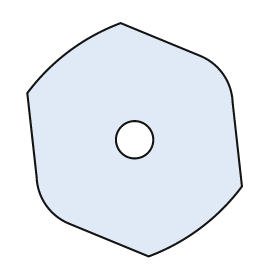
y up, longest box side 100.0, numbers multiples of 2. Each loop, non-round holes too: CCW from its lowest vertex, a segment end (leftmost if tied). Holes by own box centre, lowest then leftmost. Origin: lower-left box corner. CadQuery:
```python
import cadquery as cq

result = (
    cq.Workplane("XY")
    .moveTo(52.0, 0.0)
    .threePointArc((74.0, 12.0), (92.0, 30.0))
    .lineTo(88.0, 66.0)
    .threePointArc((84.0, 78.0), (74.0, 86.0))
    .lineTo(40.0, 100.0)
    .threePointArc((18.0, 88.0), (0.0, 70.0))
    .lineTo(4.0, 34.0)
    .threePointArc((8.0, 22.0), (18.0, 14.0))
    .close()
    .moveTo(46.0, 50.0)
    .circle(8.0)
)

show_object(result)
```